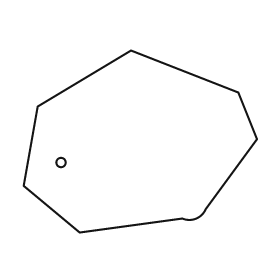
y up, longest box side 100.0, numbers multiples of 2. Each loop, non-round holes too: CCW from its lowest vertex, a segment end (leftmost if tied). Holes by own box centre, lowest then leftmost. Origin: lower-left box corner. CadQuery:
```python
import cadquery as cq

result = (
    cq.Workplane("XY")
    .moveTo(24.0, 0.0)
    .lineTo(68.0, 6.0)
    .threePointArc((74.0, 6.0), (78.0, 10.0))
    .lineTo(100.0, 40.0)
    .lineTo(92.0, 60.0)
    .lineTo(46.0, 78.0)
    .lineTo(6.0, 54.0)
    .lineTo(0.0, 20.0)
    .close()
    .moveTo(16.0, 30.0)
    .circle(2.0)
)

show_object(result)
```